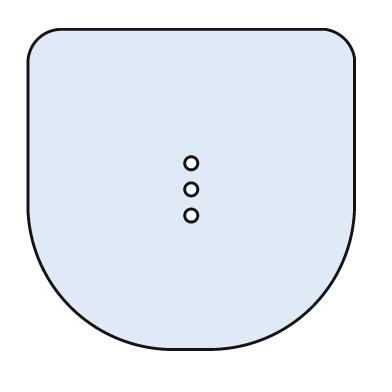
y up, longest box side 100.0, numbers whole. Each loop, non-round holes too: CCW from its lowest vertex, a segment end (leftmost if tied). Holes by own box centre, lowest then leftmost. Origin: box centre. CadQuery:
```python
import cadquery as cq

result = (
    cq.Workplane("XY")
    .moveTo(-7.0, -49.0)
    .lineTo(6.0, -49.0)
    .threePointArc((37.0, -36.0), (50.0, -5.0))
    .lineTo(50.0, 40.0)
    .threePointArc((47.0, 46.0), (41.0, 49.0))
    .lineTo(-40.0, 49.0)
    .threePointArc((-47.0, 46.0), (-50.0, 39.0))
    .lineTo(-50.0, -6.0)
    .threePointArc((-37.0, -36.0), (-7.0, -49.0))
    .close()
    .moveTo(0.0, -8.0)
    .circle(2.0)
    .moveTo(0.0, 0.0)
    .circle(2.0)
    .moveTo(0.0, 8.0)
    .circle(2.0)
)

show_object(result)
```